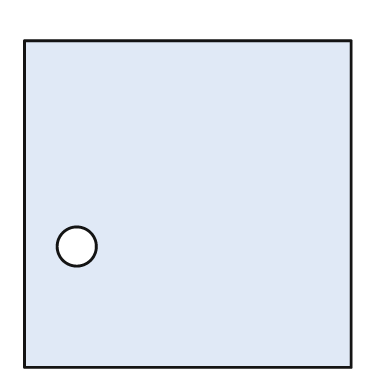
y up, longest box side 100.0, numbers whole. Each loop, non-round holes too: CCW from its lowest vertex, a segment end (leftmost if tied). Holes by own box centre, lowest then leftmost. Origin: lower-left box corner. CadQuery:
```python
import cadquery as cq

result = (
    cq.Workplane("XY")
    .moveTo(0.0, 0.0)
    .lineTo(100.0, 0.0)
    .lineTo(100.0, 100.0)
    .lineTo(0.0, 100.0)
    .close()
    .moveTo(16.0, 37.0)
    .circle(6.0)
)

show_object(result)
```